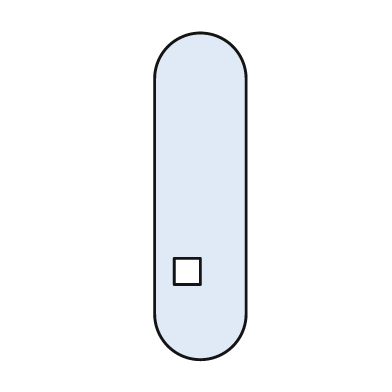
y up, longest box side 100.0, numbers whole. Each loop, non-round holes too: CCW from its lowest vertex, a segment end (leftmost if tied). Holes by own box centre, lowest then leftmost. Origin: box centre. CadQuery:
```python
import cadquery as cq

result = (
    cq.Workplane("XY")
    .moveTo(-14.0, -36.0)
    .threePointArc((0.0, -50.0), (14.0, -36.0))
    .lineTo(14.0, 36.0)
    .threePointArc((0.0, 50.0), (-14.0, 36.0))
    .close()
    .moveTo(-8.0, -27.0)
    .lineTo(0.0, -27.0)
    .lineTo(0.0, -19.0)
    .lineTo(-8.0, -19.0)
    .close()
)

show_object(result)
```